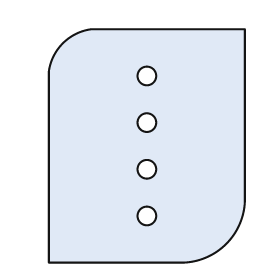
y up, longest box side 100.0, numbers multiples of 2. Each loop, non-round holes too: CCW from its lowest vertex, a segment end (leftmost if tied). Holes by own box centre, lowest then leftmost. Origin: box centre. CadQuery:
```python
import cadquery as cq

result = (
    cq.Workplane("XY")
    .moveTo(-42.0, -50.0)
    .lineTo(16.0, -50.0)
    .threePointArc((34.0, -42.0), (42.0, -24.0))
    .lineTo(42.0, 50.0)
    .lineTo(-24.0, 50.0)
    .threePointArc((-36.0, 44.0), (-42.0, 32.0))
    .close()
    .moveTo(0.0, -30.0)
    .circle(4.0)
    .moveTo(0.0, -10.0)
    .circle(4.0)
    .moveTo(0.0, 10.0)
    .circle(4.0)
    .moveTo(0.0, 30.0)
    .circle(4.0)
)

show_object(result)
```